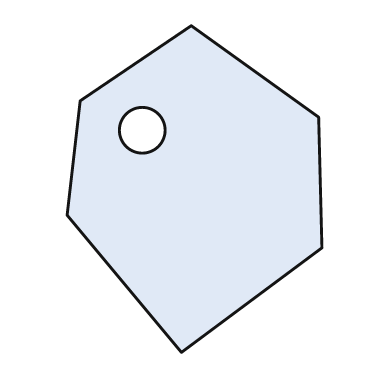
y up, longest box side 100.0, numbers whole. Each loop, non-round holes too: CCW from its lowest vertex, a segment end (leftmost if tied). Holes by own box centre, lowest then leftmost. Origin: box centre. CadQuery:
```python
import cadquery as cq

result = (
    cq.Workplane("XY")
    .moveTo(-4.0, -50.0)
    .lineTo(39.0, -18.0)
    .lineTo(38.0, 22.0)
    .lineTo(-1.0, 50.0)
    .lineTo(-35.0, 27.0)
    .lineTo(-39.0, -8.0)
    .close()
    .moveTo(-16.0, 18.0)
    .circle(7.0)
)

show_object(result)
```